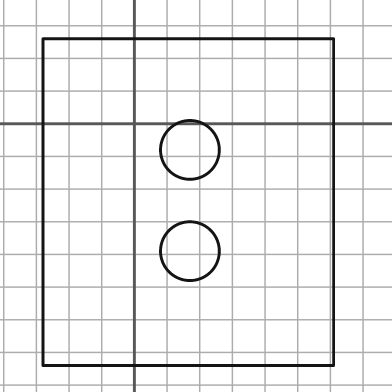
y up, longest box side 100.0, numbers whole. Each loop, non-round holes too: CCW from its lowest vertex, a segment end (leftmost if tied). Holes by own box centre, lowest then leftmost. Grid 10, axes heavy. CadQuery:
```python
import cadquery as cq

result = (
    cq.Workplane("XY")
    .moveTo(-28.0, -74.0)
    .lineTo(61.0, -74.0)
    .lineTo(61.0, 26.0)
    .lineTo(-28.0, 26.0)
    .close()
    .moveTo(17.0, -39.0)
    .circle(9.0)
    .moveTo(17.0, -8.0)
    .circle(9.0)
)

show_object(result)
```